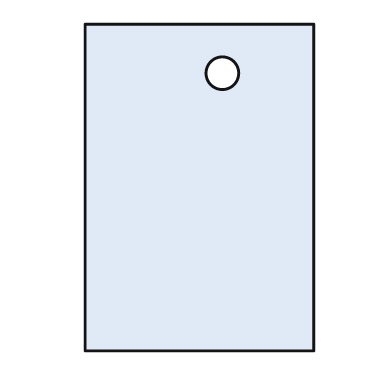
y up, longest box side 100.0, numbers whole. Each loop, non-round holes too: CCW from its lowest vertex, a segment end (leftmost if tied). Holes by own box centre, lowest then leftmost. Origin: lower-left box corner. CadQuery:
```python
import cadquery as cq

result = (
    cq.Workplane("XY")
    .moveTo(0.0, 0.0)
    .lineTo(70.0, 0.0)
    .lineTo(70.0, 100.0)
    .lineTo(0.0, 100.0)
    .close()
    .moveTo(42.0, 85.0)
    .circle(5.0)
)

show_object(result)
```